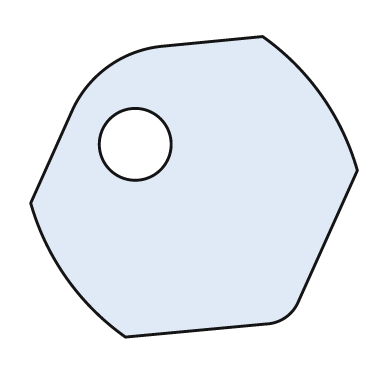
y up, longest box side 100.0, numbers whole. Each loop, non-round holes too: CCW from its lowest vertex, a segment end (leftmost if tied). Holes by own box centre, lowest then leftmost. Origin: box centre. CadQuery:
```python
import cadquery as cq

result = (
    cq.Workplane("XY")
    .moveTo(-21.0, -46.0)
    .lineTo(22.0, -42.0)
    .threePointArc((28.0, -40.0), (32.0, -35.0))
    .lineTo(50.0, 5.0)
    .threePointArc((39.0, 28.0), (21.0, 46.0))
    .lineTo(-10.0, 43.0)
    .threePointArc((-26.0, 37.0), (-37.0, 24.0))
    .lineTo(-50.0, -5.0)
    .threePointArc((-39.0, -28.0), (-21.0, -46.0))
    .close()
    .moveTo(-18.0, 13.0)
    .circle(11.0)
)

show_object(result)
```